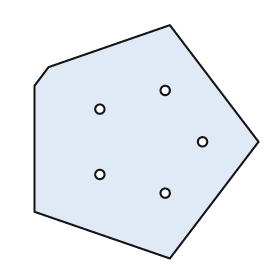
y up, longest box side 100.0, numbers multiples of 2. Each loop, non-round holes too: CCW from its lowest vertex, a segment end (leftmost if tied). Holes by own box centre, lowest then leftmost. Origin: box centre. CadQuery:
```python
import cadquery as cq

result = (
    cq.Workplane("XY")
    .moveTo(10.0, -50.0)
    .lineTo(48.0, 0.0)
    .lineTo(10.0, 50.0)
    .lineTo(-42.0, 32.0)
    .lineTo(-48.0, 24.0)
    .lineTo(-48.0, -30.0)
    .close()
    .moveTo(8.0, -22.0)
    .circle(2.0)
    .moveTo(-20.0, -14.0)
    .circle(2.0)
    .moveTo(24.0, 0.0)
    .circle(2.0)
    .moveTo(-20.0, 14.0)
    .circle(2.0)
    .moveTo(8.0, 22.0)
    .circle(2.0)
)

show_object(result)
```